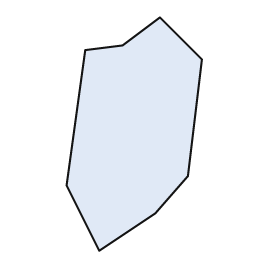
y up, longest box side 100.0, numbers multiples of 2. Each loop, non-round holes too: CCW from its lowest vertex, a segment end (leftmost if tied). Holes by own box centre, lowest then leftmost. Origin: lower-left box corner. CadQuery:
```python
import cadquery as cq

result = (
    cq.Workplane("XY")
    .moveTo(14.0, 0.0)
    .lineTo(38.0, 16.0)
    .lineTo(52.0, 32.0)
    .lineTo(58.0, 82.0)
    .lineTo(40.0, 100.0)
    .lineTo(24.0, 88.0)
    .lineTo(8.0, 86.0)
    .lineTo(0.0, 28.0)
    .close()
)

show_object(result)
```